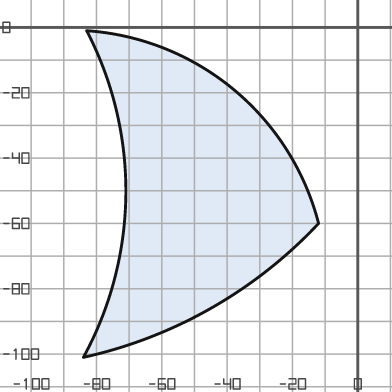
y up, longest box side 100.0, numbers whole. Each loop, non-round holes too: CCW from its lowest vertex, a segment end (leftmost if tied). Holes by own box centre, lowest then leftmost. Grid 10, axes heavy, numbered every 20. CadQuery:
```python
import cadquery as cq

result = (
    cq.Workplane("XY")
    .moveTo(-84.0, -101.0)
    .threePointArc((-45.0, -86.0), (-12.0, -60.0))
    .threePointArc((-38.0, -19.0), (-83.0, -1.0))
    .threePointArc((-71.0, -51.0), (-84.0, -101.0))
    .close()
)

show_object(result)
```